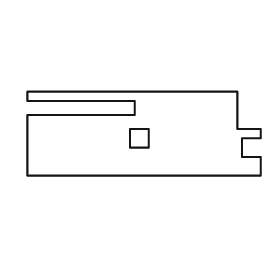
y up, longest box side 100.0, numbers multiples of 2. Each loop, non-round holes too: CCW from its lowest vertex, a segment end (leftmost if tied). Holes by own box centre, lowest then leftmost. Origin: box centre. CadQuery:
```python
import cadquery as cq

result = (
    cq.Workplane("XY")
    .moveTo(-50.0, -18.0)
    .lineTo(50.0, -18.0)
    .lineTo(50.0, -10.0)
    .lineTo(42.0, -10.0)
    .lineTo(42.0, -2.0)
    .lineTo(50.0, -2.0)
    .lineTo(50.0, 2.0)
    .lineTo(40.0, 2.0)
    .lineTo(40.0, 18.0)
    .lineTo(-50.0, 18.0)
    .lineTo(-50.0, 14.0)
    .lineTo(-4.0, 14.0)
    .lineTo(-4.0, 8.0)
    .lineTo(-50.0, 8.0)
    .close()
    .moveTo(-6.0, -6.0)
    .lineTo(2.0, -6.0)
    .lineTo(2.0, 2.0)
    .lineTo(-6.0, 2.0)
    .close()
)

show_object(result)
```